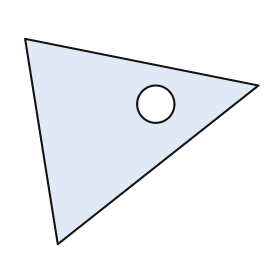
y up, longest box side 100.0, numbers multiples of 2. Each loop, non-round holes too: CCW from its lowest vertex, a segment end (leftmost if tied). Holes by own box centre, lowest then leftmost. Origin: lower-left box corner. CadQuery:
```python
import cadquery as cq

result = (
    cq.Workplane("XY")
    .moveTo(14.0, 0.0)
    .lineTo(100.0, 68.0)
    .lineTo(0.0, 88.0)
    .close()
    .moveTo(56.0, 60.0)
    .circle(8.0)
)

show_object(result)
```